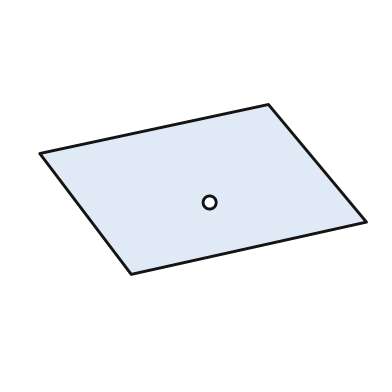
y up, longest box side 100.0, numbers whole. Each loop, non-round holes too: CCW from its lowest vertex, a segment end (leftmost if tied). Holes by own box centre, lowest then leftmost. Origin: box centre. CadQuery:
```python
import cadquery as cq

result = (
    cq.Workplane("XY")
    .moveTo(-22.0, -26.0)
    .lineTo(50.0, -10.0)
    .lineTo(20.0, 26.0)
    .lineTo(-50.0, 11.0)
    .close()
    .moveTo(2.0, -4.0)
    .circle(2.0)
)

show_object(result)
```